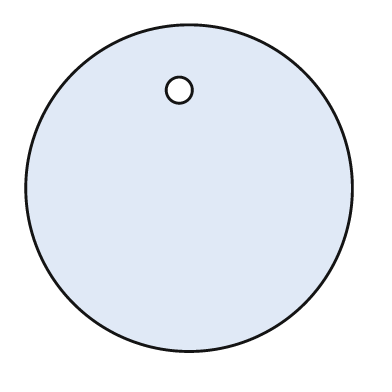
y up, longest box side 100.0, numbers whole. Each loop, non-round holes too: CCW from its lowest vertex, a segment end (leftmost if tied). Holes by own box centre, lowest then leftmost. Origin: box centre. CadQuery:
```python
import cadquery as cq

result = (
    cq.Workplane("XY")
    .moveTo(0.0, 0.0)
    .circle(50.0)
    .moveTo(-3.0, 30.0)
    .circle(4.0)
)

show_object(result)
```